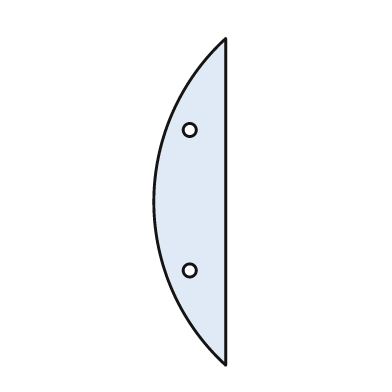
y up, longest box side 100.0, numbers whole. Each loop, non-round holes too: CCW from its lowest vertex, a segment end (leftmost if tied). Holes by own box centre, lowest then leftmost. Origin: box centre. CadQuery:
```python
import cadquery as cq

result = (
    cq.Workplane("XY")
    .moveTo(11.0, -50.0)
    .lineTo(11.0, 50.0)
    .threePointArc((-11.0, 0.0), (11.0, -50.0))
    .close()
    .moveTo(0.0, -21.0)
    .circle(2.0)
    .moveTo(0.0, 22.0)
    .circle(2.0)
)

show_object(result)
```